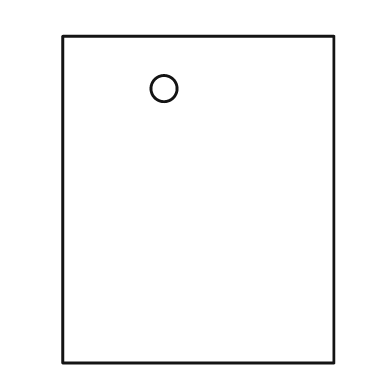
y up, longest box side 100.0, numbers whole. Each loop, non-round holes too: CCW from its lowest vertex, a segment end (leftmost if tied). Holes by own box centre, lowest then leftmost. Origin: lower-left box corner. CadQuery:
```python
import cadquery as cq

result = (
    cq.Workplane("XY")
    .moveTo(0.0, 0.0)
    .lineTo(83.0, 0.0)
    .lineTo(83.0, 100.0)
    .lineTo(0.0, 100.0)
    .close()
    .moveTo(31.0, 84.0)
    .circle(4.0)
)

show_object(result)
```